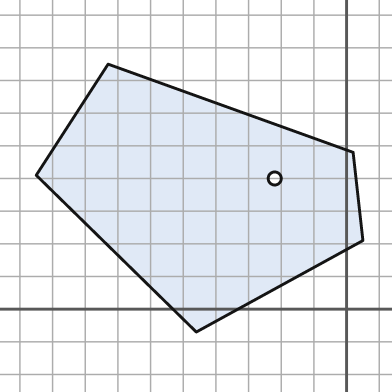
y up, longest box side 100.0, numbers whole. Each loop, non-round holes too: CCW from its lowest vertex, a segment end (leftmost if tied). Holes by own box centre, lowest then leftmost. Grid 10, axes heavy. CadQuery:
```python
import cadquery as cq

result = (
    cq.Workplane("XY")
    .moveTo(-46.0, -7.0)
    .lineTo(5.0, 21.0)
    .lineTo(2.0, 48.0)
    .lineTo(-73.0, 75.0)
    .lineTo(-95.0, 41.0)
    .close()
    .moveTo(-22.0, 40.0)
    .circle(2.0)
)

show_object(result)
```